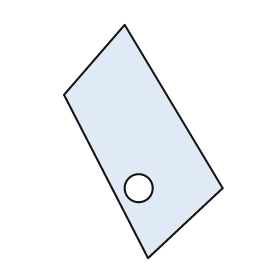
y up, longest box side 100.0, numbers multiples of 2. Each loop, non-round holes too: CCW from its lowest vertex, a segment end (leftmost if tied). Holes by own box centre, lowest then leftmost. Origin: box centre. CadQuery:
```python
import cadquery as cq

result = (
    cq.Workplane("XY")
    .moveTo(2.0, -50.0)
    .lineTo(34.0, -20.0)
    .lineTo(-8.0, 50.0)
    .lineTo(-34.0, 20.0)
    .close()
    .moveTo(-2.0, -20.0)
    .circle(6.0)
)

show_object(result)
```